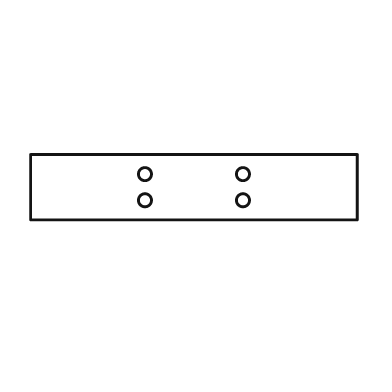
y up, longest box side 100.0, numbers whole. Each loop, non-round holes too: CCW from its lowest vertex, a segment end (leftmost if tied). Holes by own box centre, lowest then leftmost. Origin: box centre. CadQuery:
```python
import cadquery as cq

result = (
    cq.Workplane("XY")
    .moveTo(-50.0, -10.0)
    .lineTo(50.0, -10.0)
    .lineTo(50.0, 10.0)
    .lineTo(-50.0, 10.0)
    .close()
    .moveTo(-15.0, -4.0)
    .circle(2.0)
    .moveTo(15.0, -4.0)
    .circle(2.0)
    .moveTo(-15.0, 4.0)
    .circle(2.0)
    .moveTo(15.0, 4.0)
    .circle(2.0)
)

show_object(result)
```